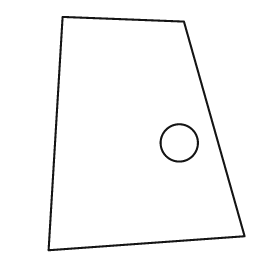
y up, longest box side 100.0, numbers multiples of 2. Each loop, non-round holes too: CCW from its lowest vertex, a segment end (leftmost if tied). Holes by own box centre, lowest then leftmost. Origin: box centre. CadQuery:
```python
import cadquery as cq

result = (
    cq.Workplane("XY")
    .moveTo(-42.0, -50.0)
    .lineTo(42.0, -44.0)
    .lineTo(16.0, 48.0)
    .lineTo(-36.0, 50.0)
    .close()
    .moveTo(14.0, -4.0)
    .circle(8.0)
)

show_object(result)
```